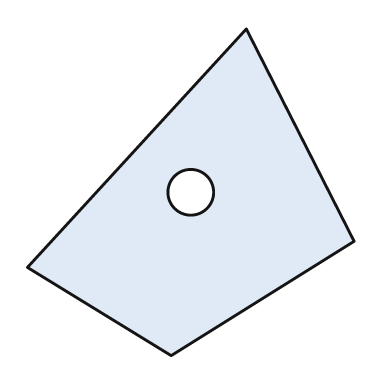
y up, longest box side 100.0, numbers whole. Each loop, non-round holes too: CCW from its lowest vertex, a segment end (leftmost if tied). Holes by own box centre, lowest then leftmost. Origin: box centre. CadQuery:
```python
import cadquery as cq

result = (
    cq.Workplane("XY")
    .moveTo(-6.0, -50.0)
    .lineTo(50.0, -15.0)
    .lineTo(17.0, 50.0)
    .lineTo(-50.0, -23.0)
    .close()
    .moveTo(0.0, 0.0)
    .circle(7.0)
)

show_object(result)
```